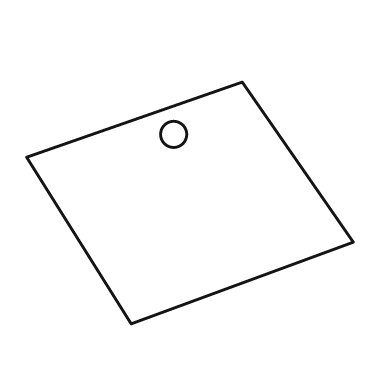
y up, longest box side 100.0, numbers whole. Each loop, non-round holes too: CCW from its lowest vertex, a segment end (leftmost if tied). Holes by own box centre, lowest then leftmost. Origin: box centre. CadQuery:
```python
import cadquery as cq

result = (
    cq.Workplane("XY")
    .moveTo(-18.0, -37.0)
    .lineTo(50.0, -12.0)
    .lineTo(16.0, 37.0)
    .lineTo(-50.0, 14.0)
    .close()
    .moveTo(-5.0, 21.0)
    .circle(4.0)
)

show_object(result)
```